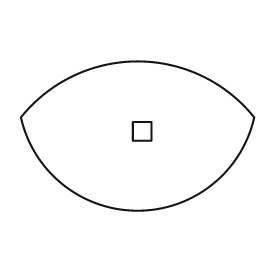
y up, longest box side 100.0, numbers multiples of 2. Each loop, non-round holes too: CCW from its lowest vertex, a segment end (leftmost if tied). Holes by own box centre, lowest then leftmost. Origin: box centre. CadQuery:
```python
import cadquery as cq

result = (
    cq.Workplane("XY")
    .moveTo(-50.0, 8.0)
    .threePointArc((0.0, -32.0), (50.0, 8.0))
    .threePointArc((0.0, 32.0), (-50.0, 8.0))
    .close()
    .moveTo(-2.0, -2.0)
    .lineTo(6.0, -2.0)
    .lineTo(6.0, 6.0)
    .lineTo(-2.0, 6.0)
    .close()
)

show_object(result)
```